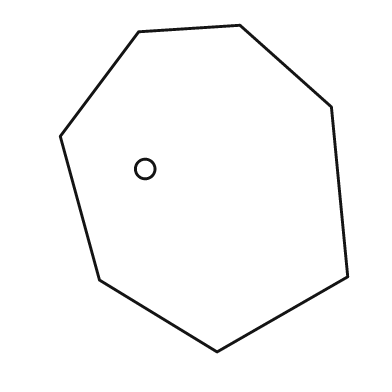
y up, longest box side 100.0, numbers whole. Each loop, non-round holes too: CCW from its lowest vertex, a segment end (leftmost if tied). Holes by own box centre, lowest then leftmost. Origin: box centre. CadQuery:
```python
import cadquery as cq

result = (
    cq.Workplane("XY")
    .moveTo(4.0, -50.0)
    .lineTo(44.0, -27.0)
    .lineTo(39.0, 25.0)
    .lineTo(11.0, 50.0)
    .lineTo(-20.0, 48.0)
    .lineTo(-44.0, 16.0)
    .lineTo(-32.0, -28.0)
    .close()
    .moveTo(-18.0, 6.0)
    .circle(3.0)
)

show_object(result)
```